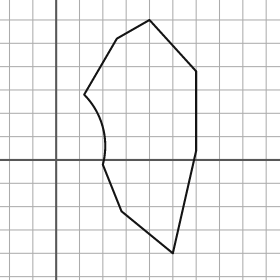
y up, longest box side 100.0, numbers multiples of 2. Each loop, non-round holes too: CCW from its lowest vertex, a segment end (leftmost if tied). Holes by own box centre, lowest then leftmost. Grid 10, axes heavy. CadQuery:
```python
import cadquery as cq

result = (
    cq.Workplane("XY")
    .moveTo(50.0, -40.0)
    .lineTo(60.0, 4.0)
    .lineTo(60.0, 38.0)
    .lineTo(40.0, 60.0)
    .lineTo(26.0, 52.0)
    .lineTo(12.0, 28.0)
    .threePointArc((20.0, 14.0), (20.0, -2.0))
    .lineTo(28.0, -22.0)
    .close()
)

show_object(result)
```